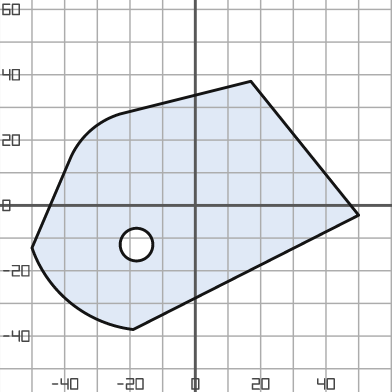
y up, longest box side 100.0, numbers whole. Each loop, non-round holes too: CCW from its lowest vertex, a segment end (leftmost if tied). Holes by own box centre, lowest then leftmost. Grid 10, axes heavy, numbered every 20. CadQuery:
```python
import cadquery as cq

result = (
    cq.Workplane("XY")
    .moveTo(-19.0, -38.0)
    .lineTo(50.0, -3.0)
    .lineTo(17.0, 38.0)
    .lineTo(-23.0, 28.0)
    .threePointArc((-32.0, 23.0), (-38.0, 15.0))
    .lineTo(-50.0, -13.0)
    .threePointArc((-38.0, -30.0), (-19.0, -38.0))
    .close()
    .moveTo(-18.0, -12.0)
    .circle(5.0)
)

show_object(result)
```